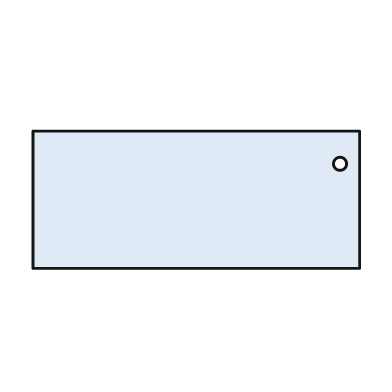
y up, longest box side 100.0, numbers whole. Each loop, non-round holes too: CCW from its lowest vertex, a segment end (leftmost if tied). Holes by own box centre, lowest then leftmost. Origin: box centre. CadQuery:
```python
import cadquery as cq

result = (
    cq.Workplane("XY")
    .moveTo(-50.0, -21.0)
    .lineTo(50.0, -21.0)
    .lineTo(50.0, 21.0)
    .lineTo(-50.0, 21.0)
    .close()
    .moveTo(44.0, 11.0)
    .circle(2.0)
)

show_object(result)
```